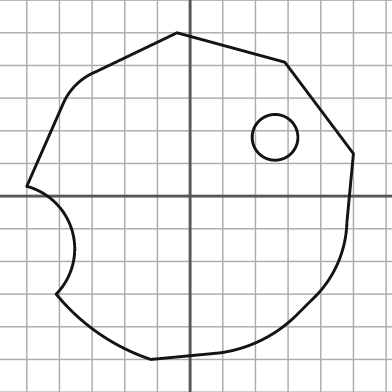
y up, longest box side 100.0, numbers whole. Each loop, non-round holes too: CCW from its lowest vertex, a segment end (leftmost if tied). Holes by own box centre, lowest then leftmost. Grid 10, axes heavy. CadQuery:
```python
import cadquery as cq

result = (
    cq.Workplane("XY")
    .moveTo(-12.0, -50.0)
    .lineTo(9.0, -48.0)
    .threePointArc((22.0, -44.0), (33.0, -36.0))
    .lineTo(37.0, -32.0)
    .threePointArc((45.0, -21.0), (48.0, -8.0))
    .lineTo(50.0, 13.0)
    .lineTo(29.0, 41.0)
    .lineTo(-4.0, 50.0)
    .lineTo(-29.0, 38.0)
    .threePointArc((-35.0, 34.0), (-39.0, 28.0))
    .lineTo(-50.0, 3.0)
    .threePointArc((-36.0, -11.0), (-41.0, -30.0))
    .threePointArc((-28.0, -42.0), (-12.0, -50.0))
    .close()
    .moveTo(26.0, 18.0)
    .circle(7.0)
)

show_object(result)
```